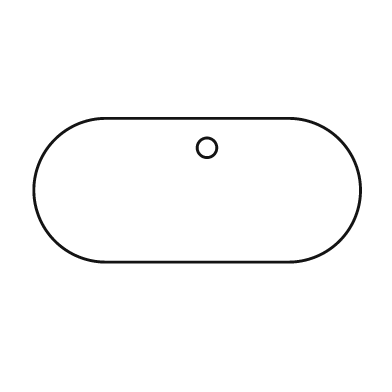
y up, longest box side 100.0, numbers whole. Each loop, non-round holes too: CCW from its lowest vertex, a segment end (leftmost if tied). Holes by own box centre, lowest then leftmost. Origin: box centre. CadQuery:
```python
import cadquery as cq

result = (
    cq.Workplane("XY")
    .moveTo(-28.0, -22.0)
    .lineTo(28.0, -22.0)
    .threePointArc((50.0, 0.0), (28.0, 22.0))
    .lineTo(-28.0, 22.0)
    .threePointArc((-50.0, 0.0), (-28.0, -22.0))
    .close()
    .moveTo(3.0, 13.0)
    .circle(3.0)
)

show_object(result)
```